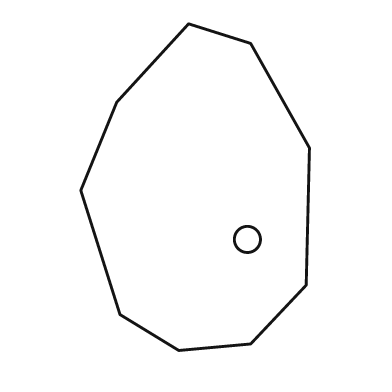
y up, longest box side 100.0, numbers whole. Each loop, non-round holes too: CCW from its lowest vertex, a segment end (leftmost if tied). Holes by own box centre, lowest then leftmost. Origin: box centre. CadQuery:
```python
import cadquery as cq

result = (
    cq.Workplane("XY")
    .moveTo(-5.0, -50.0)
    .lineTo(17.0, -48.0)
    .lineTo(34.0, -30.0)
    .lineTo(35.0, 12.0)
    .lineTo(17.0, 44.0)
    .lineTo(-2.0, 50.0)
    .lineTo(-24.0, 26.0)
    .lineTo(-35.0, -1.0)
    .lineTo(-23.0, -39.0)
    .close()
    .moveTo(16.0, -16.0)
    .circle(4.0)
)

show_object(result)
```